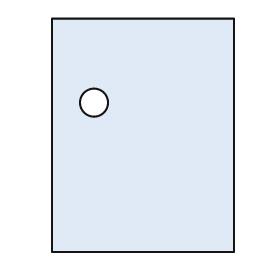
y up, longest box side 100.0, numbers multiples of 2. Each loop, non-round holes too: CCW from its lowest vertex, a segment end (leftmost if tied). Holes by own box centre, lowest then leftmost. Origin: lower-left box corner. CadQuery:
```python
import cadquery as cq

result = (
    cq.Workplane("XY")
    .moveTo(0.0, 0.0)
    .lineTo(78.0, 0.0)
    .lineTo(78.0, 100.0)
    .lineTo(0.0, 100.0)
    .close()
    .moveTo(18.0, 64.0)
    .circle(6.0)
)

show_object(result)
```